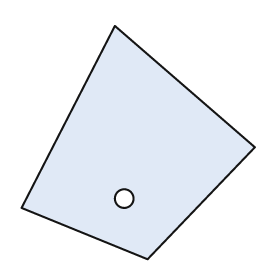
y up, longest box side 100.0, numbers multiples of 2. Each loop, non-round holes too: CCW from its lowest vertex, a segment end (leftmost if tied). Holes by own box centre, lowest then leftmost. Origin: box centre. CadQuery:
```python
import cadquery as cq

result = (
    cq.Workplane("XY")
    .moveTo(4.0, -50.0)
    .lineTo(50.0, -2.0)
    .lineTo(-10.0, 50.0)
    .lineTo(-50.0, -28.0)
    .close()
    .moveTo(-6.0, -24.0)
    .circle(4.0)
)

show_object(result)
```